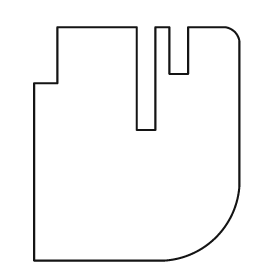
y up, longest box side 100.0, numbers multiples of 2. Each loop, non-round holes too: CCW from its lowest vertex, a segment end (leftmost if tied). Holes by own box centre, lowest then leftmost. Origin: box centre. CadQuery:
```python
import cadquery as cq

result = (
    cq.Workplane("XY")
    .moveTo(-44.0, -50.0)
    .lineTo(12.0, -50.0)
    .threePointArc((34.0, -40.0), (44.0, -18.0))
    .lineTo(44.0, 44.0)
    .threePointArc((42.0, 48.0), (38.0, 50.0))
    .lineTo(22.0, 50.0)
    .lineTo(22.0, 30.0)
    .lineTo(14.0, 30.0)
    .lineTo(14.0, 50.0)
    .lineTo(8.0, 50.0)
    .lineTo(8.0, 6.0)
    .lineTo(0.0, 6.0)
    .lineTo(0.0, 50.0)
    .lineTo(-34.0, 50.0)
    .lineTo(-34.0, 26.0)
    .lineTo(-44.0, 26.0)
    .close()
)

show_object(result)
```